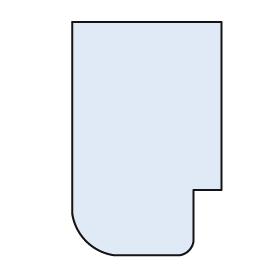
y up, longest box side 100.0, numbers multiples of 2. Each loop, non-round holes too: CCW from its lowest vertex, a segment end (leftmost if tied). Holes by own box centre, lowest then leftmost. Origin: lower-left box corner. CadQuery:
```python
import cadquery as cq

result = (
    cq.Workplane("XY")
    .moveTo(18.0, 0.0)
    .lineTo(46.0, 0.0)
    .threePointArc((50.0, 2.0), (52.0, 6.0))
    .lineTo(52.0, 28.0)
    .lineTo(64.0, 28.0)
    .lineTo(64.0, 100.0)
    .lineTo(0.0, 100.0)
    .lineTo(0.0, 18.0)
    .threePointArc((6.0, 6.0), (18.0, 0.0))
    .close()
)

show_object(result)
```